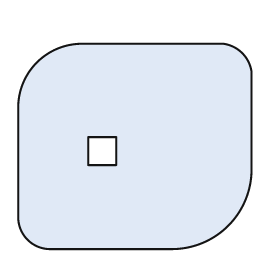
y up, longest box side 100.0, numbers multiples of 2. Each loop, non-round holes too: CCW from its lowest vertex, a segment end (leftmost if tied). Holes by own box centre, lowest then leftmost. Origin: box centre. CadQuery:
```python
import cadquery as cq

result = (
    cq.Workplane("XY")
    .moveTo(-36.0, -44.0)
    .lineTo(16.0, -44.0)
    .threePointArc((40.0, -34.0), (50.0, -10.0))
    .lineTo(50.0, 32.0)
    .threePointArc((46.0, 40.0), (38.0, 44.0))
    .lineTo(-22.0, 44.0)
    .threePointArc((-42.0, 36.0), (-50.0, 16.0))
    .lineTo(-50.0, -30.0)
    .threePointArc((-46.0, -40.0), (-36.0, -44.0))
    .close()
    .moveTo(-20.0, -8.0)
    .lineTo(-8.0, -8.0)
    .lineTo(-8.0, 4.0)
    .lineTo(-20.0, 4.0)
    .close()
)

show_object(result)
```